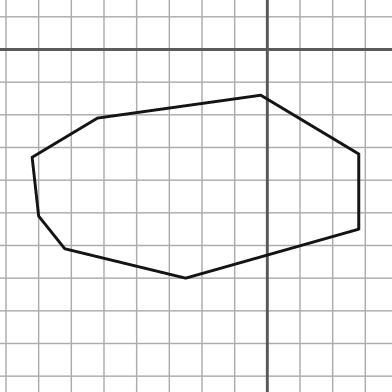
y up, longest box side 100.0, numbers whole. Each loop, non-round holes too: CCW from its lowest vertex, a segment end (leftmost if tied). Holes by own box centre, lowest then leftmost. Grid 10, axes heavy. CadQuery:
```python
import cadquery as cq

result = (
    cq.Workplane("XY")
    .moveTo(-25.0, -70.0)
    .lineTo(28.0, -55.0)
    .lineTo(28.0, -32.0)
    .lineTo(-2.0, -14.0)
    .lineTo(-52.0, -21.0)
    .lineTo(-72.0, -33.0)
    .lineTo(-70.0, -51.0)
    .lineTo(-62.0, -61.0)
    .close()
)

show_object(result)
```